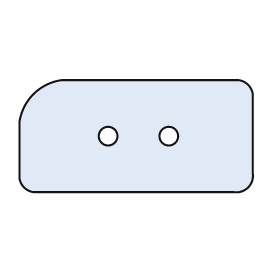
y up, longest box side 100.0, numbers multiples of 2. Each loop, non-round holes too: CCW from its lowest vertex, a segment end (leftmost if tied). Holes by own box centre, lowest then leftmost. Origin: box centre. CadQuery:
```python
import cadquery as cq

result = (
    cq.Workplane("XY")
    .moveTo(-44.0, -24.0)
    .lineTo(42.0, -24.0)
    .threePointArc((48.0, -22.0), (50.0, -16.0))
    .lineTo(50.0, 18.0)
    .threePointArc((48.0, 22.0), (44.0, 24.0))
    .lineTo(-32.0, 24.0)
    .threePointArc((-44.0, 18.0), (-50.0, 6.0))
    .lineTo(-50.0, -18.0)
    .threePointArc((-48.0, -22.0), (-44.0, -24.0))
    .close()
    .moveTo(-12.0, 0.0)
    .circle(4.0)
    .moveTo(14.0, 0.0)
    .circle(4.0)
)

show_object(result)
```